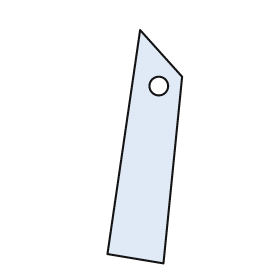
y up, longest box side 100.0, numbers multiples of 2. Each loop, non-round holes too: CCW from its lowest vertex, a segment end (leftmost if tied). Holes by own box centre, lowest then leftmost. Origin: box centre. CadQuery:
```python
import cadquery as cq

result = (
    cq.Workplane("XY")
    .moveTo(8.0, -50.0)
    .lineTo(16.0, 30.0)
    .lineTo(-2.0, 50.0)
    .lineTo(-16.0, -46.0)
    .close()
    .moveTo(6.0, 26.0)
    .circle(4.0)
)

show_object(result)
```